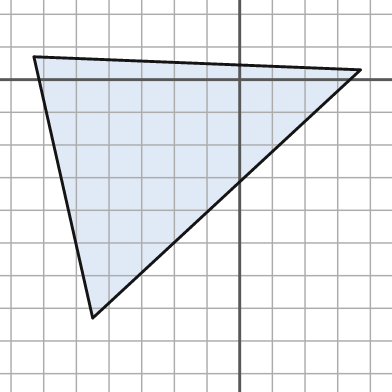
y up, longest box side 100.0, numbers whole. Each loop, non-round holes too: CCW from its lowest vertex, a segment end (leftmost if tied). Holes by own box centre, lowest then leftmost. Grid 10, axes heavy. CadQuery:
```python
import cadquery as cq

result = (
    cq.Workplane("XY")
    .moveTo(-45.0, -73.0)
    .lineTo(37.0, 3.0)
    .lineTo(-63.0, 7.0)
    .close()
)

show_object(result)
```